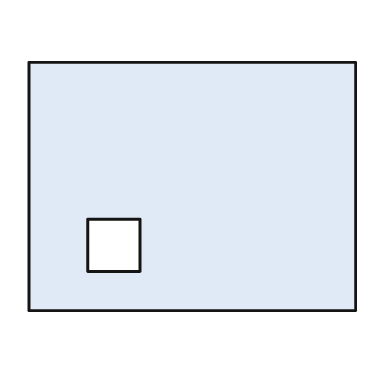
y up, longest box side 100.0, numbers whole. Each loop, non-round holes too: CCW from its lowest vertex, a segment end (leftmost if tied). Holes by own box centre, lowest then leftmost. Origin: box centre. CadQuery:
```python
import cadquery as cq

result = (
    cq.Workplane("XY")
    .moveTo(-50.0, -38.0)
    .lineTo(50.0, -38.0)
    .lineTo(50.0, 38.0)
    .lineTo(-50.0, 38.0)
    .close()
    .moveTo(-32.0, -26.0)
    .lineTo(-16.0, -26.0)
    .lineTo(-16.0, -10.0)
    .lineTo(-32.0, -10.0)
    .close()
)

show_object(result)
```